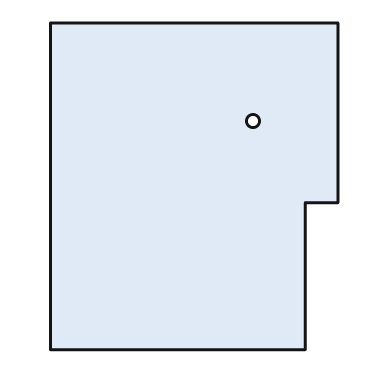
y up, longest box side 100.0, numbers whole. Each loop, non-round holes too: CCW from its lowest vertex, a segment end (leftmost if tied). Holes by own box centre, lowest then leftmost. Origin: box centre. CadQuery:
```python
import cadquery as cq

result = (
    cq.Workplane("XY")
    .moveTo(-44.0, -50.0)
    .lineTo(34.0, -50.0)
    .lineTo(34.0, -5.0)
    .lineTo(44.0, -5.0)
    .lineTo(44.0, 50.0)
    .lineTo(-44.0, 50.0)
    .close()
    .moveTo(18.0, 20.0)
    .circle(2.0)
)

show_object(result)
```